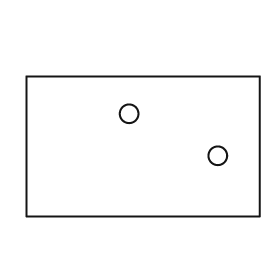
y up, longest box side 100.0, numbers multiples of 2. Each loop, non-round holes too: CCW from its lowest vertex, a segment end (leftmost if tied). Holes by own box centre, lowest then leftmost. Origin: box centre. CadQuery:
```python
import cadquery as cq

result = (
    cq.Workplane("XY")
    .moveTo(-50.0, -30.0)
    .lineTo(50.0, -30.0)
    .lineTo(50.0, 30.0)
    .lineTo(-50.0, 30.0)
    .close()
    .moveTo(32.0, -4.0)
    .circle(4.0)
    .moveTo(-6.0, 14.0)
    .circle(4.0)
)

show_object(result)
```